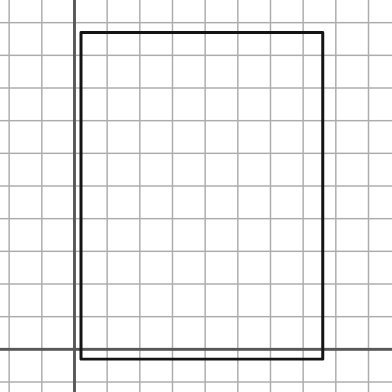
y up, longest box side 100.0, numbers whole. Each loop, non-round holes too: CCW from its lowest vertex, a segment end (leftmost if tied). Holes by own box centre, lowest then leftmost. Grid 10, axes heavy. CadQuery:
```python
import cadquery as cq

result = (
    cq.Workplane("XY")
    .moveTo(2.0, -3.0)
    .lineTo(76.0, -3.0)
    .lineTo(76.0, 97.0)
    .lineTo(2.0, 97.0)
    .close()
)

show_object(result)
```